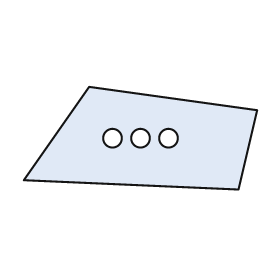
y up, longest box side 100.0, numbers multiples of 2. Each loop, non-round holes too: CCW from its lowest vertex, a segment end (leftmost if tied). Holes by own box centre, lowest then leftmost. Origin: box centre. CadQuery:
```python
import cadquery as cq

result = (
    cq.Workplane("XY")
    .moveTo(42.0, -22.0)
    .lineTo(50.0, 12.0)
    .lineTo(-22.0, 22.0)
    .lineTo(-50.0, -18.0)
    .close()
    .moveTo(-12.0, 0.0)
    .circle(4.0)
    .moveTo(0.0, 0.0)
    .circle(4.0)
    .moveTo(12.0, 0.0)
    .circle(4.0)
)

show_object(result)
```